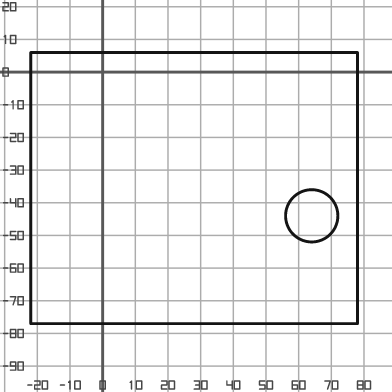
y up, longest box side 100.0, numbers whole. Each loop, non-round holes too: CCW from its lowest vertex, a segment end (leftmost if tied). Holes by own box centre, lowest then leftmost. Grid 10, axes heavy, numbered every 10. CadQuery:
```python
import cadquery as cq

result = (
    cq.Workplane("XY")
    .moveTo(-22.0, -77.0)
    .lineTo(78.0, -77.0)
    .lineTo(78.0, 6.0)
    .lineTo(-22.0, 6.0)
    .close()
    .moveTo(64.0, -44.0)
    .circle(8.0)
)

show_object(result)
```